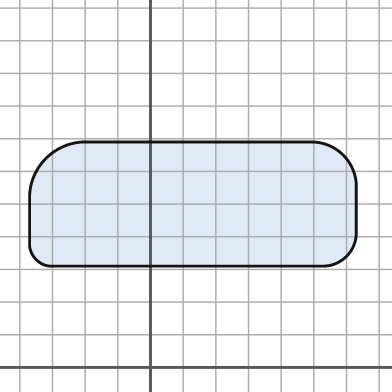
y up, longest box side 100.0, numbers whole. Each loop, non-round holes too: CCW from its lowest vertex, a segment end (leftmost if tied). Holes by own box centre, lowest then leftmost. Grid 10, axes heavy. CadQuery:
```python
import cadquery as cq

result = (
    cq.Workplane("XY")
    .moveTo(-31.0, 31.0)
    .lineTo(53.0, 31.0)
    .threePointArc((60.0, 34.0), (63.0, 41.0))
    .lineTo(63.0, 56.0)
    .threePointArc((59.0, 65.0), (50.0, 69.0))
    .lineTo(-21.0, 69.0)
    .threePointArc((-32.0, 64.0), (-37.0, 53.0))
    .lineTo(-37.0, 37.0)
    .threePointArc((-35.0, 33.0), (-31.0, 31.0))
    .close()
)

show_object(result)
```